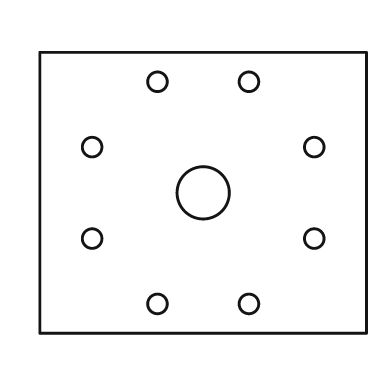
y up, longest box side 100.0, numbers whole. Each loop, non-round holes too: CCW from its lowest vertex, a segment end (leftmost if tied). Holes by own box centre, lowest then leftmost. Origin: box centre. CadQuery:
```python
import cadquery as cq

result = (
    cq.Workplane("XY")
    .moveTo(-50.0, -43.0)
    .lineTo(50.0, -43.0)
    .lineTo(50.0, 43.0)
    .lineTo(-50.0, 43.0)
    .close()
    .moveTo(-14.0, -34.0)
    .circle(3.0)
    .moveTo(14.0, -34.0)
    .circle(3.0)
    .moveTo(-34.0, -14.0)
    .circle(3.0)
    .moveTo(34.0, -14.0)
    .circle(3.0)
    .moveTo(0.0, 0.0)
    .circle(8.0)
    .moveTo(-34.0, 14.0)
    .circle(3.0)
    .moveTo(34.0, 14.0)
    .circle(3.0)
    .moveTo(-14.0, 34.0)
    .circle(3.0)
    .moveTo(14.0, 34.0)
    .circle(3.0)
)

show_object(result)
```